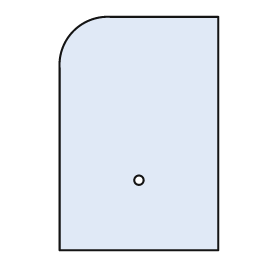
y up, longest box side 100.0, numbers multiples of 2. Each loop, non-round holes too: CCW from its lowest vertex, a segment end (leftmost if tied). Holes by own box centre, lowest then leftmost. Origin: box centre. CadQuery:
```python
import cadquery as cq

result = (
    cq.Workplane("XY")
    .moveTo(-34.0, -50.0)
    .lineTo(34.0, -50.0)
    .lineTo(34.0, 50.0)
    .lineTo(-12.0, 50.0)
    .threePointArc((-28.0, 44.0), (-34.0, 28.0))
    .close()
    .moveTo(0.0, -20.0)
    .circle(2.0)
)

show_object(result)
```